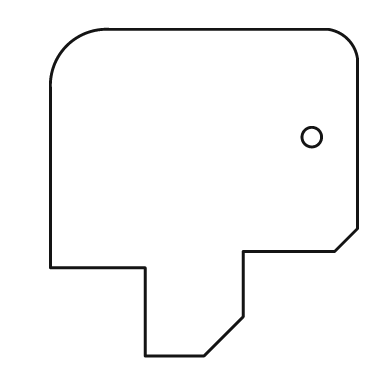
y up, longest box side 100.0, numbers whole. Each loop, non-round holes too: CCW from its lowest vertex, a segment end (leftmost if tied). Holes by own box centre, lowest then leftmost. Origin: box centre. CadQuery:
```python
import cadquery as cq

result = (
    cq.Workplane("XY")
    .moveTo(-18.0, -50.0)
    .lineTo(0.0, -50.0)
    .lineTo(12.0, -38.0)
    .lineTo(12.0, -18.0)
    .lineTo(40.0, -18.0)
    .lineTo(47.0, -11.0)
    .lineTo(47.0, 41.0)
    .threePointArc((44.0, 47.0), (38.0, 50.0))
    .lineTo(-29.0, 50.0)
    .threePointArc((-42.0, 45.0), (-47.0, 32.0))
    .lineTo(-47.0, -23.0)
    .lineTo(-18.0, -23.0)
    .close()
    .moveTo(33.0, 17.0)
    .circle(3.0)
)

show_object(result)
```